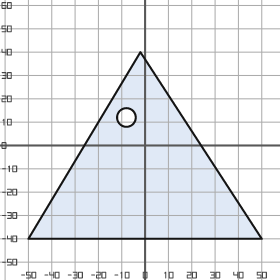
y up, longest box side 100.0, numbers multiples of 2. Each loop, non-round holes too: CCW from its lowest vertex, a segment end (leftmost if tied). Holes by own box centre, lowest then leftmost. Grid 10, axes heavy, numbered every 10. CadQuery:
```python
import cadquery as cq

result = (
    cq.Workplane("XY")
    .moveTo(-50.0, -40.0)
    .lineTo(50.0, -40.0)
    .lineTo(-2.0, 40.0)
    .close()
    .moveTo(-8.0, 12.0)
    .circle(4.0)
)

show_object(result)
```